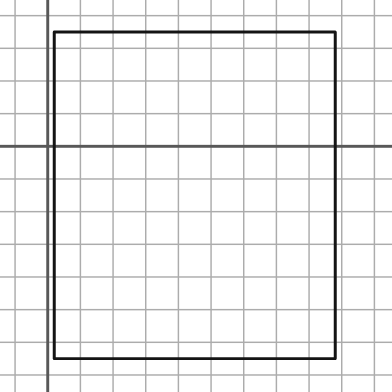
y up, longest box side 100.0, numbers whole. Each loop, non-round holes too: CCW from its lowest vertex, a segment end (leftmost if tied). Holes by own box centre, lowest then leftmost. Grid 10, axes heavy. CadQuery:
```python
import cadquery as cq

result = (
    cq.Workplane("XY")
    .moveTo(2.0, -65.0)
    .lineTo(88.0, -65.0)
    .lineTo(88.0, 35.0)
    .lineTo(2.0, 35.0)
    .close()
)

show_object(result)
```